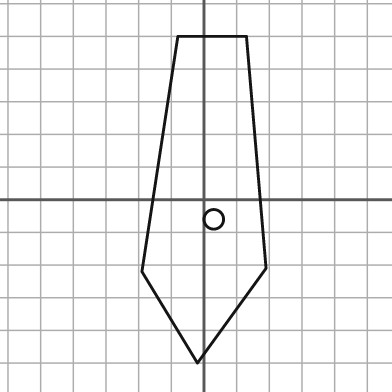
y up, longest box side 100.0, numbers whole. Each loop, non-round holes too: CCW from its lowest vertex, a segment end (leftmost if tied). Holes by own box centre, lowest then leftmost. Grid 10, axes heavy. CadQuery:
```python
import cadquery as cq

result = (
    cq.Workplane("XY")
    .moveTo(-2.0, -50.0)
    .lineTo(19.0, -21.0)
    .lineTo(13.0, 50.0)
    .lineTo(-8.0, 50.0)
    .lineTo(-19.0, -22.0)
    .close()
    .moveTo(3.0, -6.0)
    .circle(3.0)
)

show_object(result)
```